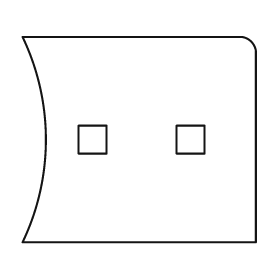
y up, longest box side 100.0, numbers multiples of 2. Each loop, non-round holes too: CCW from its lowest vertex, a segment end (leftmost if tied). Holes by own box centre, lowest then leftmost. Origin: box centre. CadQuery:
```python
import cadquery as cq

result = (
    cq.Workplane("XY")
    .moveTo(-50.0, -44.0)
    .lineTo(50.0, -44.0)
    .lineTo(50.0, 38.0)
    .threePointArc((48.0, 42.0), (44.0, 44.0))
    .lineTo(-50.0, 44.0)
    .threePointArc((-40.0, 0.0), (-50.0, -44.0))
    .close()
    .moveTo(-26.0, -6.0)
    .lineTo(-14.0, -6.0)
    .lineTo(-14.0, 6.0)
    .lineTo(-26.0, 6.0)
    .close()
    .moveTo(16.0, -6.0)
    .lineTo(28.0, -6.0)
    .lineTo(28.0, 6.0)
    .lineTo(16.0, 6.0)
    .close()
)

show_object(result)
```